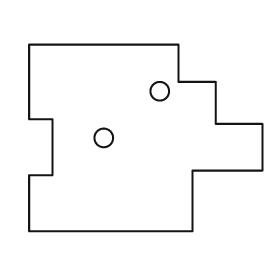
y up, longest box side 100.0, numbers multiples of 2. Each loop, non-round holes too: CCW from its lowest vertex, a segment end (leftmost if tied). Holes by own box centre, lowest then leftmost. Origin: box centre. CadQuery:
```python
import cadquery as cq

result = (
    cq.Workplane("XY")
    .moveTo(-50.0, -40.0)
    .lineTo(20.0, -40.0)
    .lineTo(20.0, -14.0)
    .lineTo(50.0, -14.0)
    .lineTo(50.0, 6.0)
    .lineTo(30.0, 6.0)
    .lineTo(30.0, 24.0)
    .lineTo(14.0, 24.0)
    .lineTo(14.0, 40.0)
    .lineTo(-50.0, 40.0)
    .lineTo(-50.0, 8.0)
    .lineTo(-40.0, 8.0)
    .lineTo(-40.0, -16.0)
    .lineTo(-50.0, -16.0)
    .close()
    .moveTo(-18.0, 0.0)
    .circle(4.0)
    .moveTo(6.0, 20.0)
    .circle(4.0)
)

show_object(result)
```